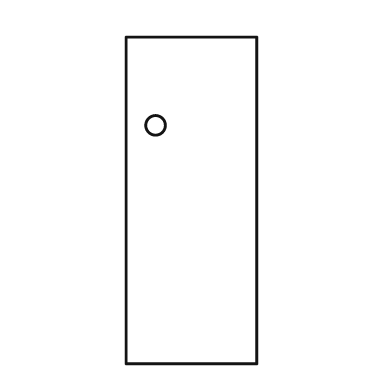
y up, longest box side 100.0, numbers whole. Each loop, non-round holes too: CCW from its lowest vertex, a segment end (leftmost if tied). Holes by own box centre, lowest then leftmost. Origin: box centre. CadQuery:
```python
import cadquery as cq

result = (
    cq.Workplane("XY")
    .moveTo(-20.0, -50.0)
    .lineTo(20.0, -50.0)
    .lineTo(20.0, 50.0)
    .lineTo(-20.0, 50.0)
    .close()
    .moveTo(-11.0, 23.0)
    .circle(3.0)
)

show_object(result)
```